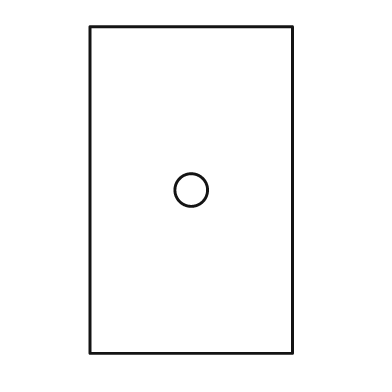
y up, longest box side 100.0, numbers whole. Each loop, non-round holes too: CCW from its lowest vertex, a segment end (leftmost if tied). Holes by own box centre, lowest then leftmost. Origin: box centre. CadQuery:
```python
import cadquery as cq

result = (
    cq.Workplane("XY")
    .moveTo(-31.0, -50.0)
    .lineTo(31.0, -50.0)
    .lineTo(31.0, 50.0)
    .lineTo(-31.0, 50.0)
    .close()
    .moveTo(0.0, 0.0)
    .circle(5.0)
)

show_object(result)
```